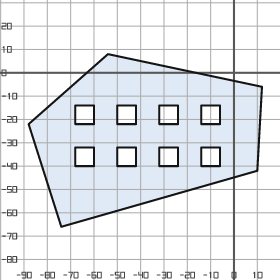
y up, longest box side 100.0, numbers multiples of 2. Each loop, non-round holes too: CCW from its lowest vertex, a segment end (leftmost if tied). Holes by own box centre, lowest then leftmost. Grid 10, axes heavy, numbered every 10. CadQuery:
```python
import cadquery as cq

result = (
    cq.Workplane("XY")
    .moveTo(-74.0, -66.0)
    .lineTo(10.0, -42.0)
    .lineTo(12.0, -6.0)
    .lineTo(-54.0, 8.0)
    .lineTo(-88.0, -22.0)
    .close()
    .moveTo(-68.0, -40.0)
    .lineTo(-60.0, -40.0)
    .lineTo(-60.0, -32.0)
    .lineTo(-68.0, -32.0)
    .close()
    .moveTo(-50.0, -40.0)
    .lineTo(-42.0, -40.0)
    .lineTo(-42.0, -32.0)
    .lineTo(-50.0, -32.0)
    .close()
    .moveTo(-32.0, -40.0)
    .lineTo(-24.0, -40.0)
    .lineTo(-24.0, -32.0)
    .lineTo(-32.0, -32.0)
    .close()
    .moveTo(-14.0, -40.0)
    .lineTo(-6.0, -40.0)
    .lineTo(-6.0, -32.0)
    .lineTo(-14.0, -32.0)
    .close()
    .moveTo(-68.0, -22.0)
    .lineTo(-60.0, -22.0)
    .lineTo(-60.0, -14.0)
    .lineTo(-68.0, -14.0)
    .close()
    .moveTo(-50.0, -22.0)
    .lineTo(-42.0, -22.0)
    .lineTo(-42.0, -14.0)
    .lineTo(-50.0, -14.0)
    .close()
    .moveTo(-32.0, -22.0)
    .lineTo(-24.0, -22.0)
    .lineTo(-24.0, -14.0)
    .lineTo(-32.0, -14.0)
    .close()
    .moveTo(-14.0, -22.0)
    .lineTo(-6.0, -22.0)
    .lineTo(-6.0, -14.0)
    .lineTo(-14.0, -14.0)
    .close()
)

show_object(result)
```